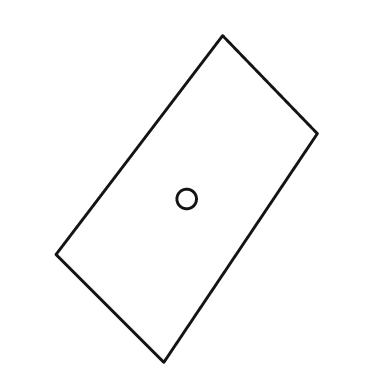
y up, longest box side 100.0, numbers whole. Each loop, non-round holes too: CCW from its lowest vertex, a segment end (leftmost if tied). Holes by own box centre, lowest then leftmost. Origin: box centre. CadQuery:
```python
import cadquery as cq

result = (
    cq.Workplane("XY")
    .moveTo(-7.0, -50.0)
    .lineTo(40.0, 20.0)
    .lineTo(11.0, 50.0)
    .lineTo(-40.0, -17.0)
    .close()
    .moveTo(0.0, 0.0)
    .circle(3.0)
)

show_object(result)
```